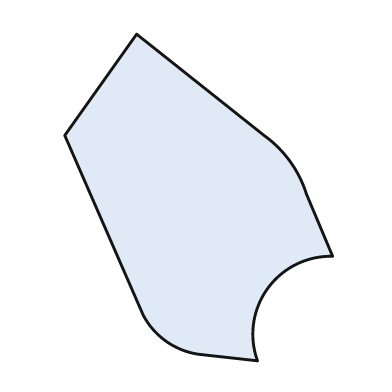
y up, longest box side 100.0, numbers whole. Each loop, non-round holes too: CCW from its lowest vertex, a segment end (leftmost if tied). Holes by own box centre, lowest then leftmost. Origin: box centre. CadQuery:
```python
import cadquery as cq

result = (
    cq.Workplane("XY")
    .moveTo(18.0, -50.0)
    .threePointArc((21.0, -28.0), (41.0, -18.0))
    .lineTo(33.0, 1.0)
    .threePointArc((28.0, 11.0), (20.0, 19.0))
    .lineTo(-19.0, 50.0)
    .lineTo(-41.0, 19.0)
    .lineTo(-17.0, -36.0)
    .threePointArc((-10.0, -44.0), (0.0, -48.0))
    .close()
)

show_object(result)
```